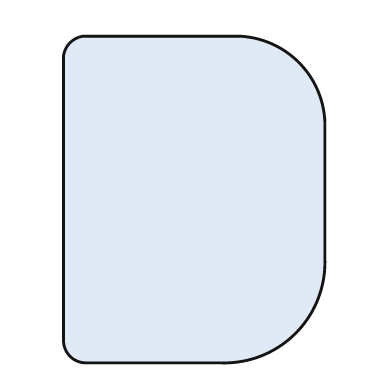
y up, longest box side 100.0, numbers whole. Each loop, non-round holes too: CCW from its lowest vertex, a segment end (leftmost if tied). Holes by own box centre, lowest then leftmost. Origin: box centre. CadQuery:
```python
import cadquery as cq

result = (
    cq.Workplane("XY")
    .moveTo(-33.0, -50.0)
    .lineTo(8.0, -50.0)
    .threePointArc((31.0, -41.0), (40.0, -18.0))
    .lineTo(40.0, 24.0)
    .threePointArc((32.0, 42.0), (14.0, 50.0))
    .lineTo(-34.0, 50.0)
    .threePointArc((-38.0, 48.0), (-40.0, 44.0))
    .lineTo(-40.0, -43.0)
    .threePointArc((-38.0, -48.0), (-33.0, -50.0))
    .close()
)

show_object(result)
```